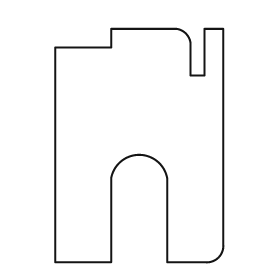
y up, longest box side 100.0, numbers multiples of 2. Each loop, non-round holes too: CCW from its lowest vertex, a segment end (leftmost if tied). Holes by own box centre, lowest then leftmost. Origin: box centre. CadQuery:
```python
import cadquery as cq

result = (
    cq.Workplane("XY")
    .moveTo(-36.0, -50.0)
    .lineTo(-12.0, -50.0)
    .lineTo(-12.0, -14.0)
    .threePointArc((0.0, -4.0), (12.0, -14.0))
    .lineTo(12.0, -50.0)
    .lineTo(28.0, -50.0)
    .threePointArc((34.0, -48.0), (36.0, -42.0))
    .lineTo(36.0, 50.0)
    .lineTo(28.0, 50.0)
    .lineTo(28.0, 30.0)
    .lineTo(22.0, 30.0)
    .lineTo(22.0, 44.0)
    .threePointArc((20.0, 48.0), (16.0, 50.0))
    .lineTo(-12.0, 50.0)
    .lineTo(-12.0, 42.0)
    .lineTo(-36.0, 42.0)
    .close()
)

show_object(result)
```